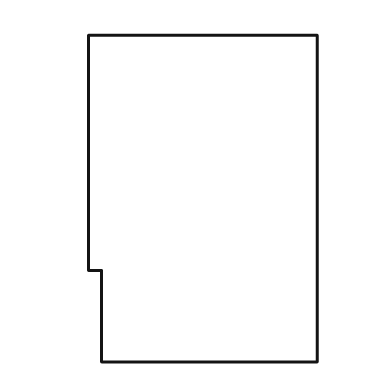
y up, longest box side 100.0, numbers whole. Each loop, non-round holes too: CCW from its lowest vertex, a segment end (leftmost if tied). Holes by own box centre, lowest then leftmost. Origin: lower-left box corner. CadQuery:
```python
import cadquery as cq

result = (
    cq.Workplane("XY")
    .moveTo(4.0, 0.0)
    .lineTo(70.0, 0.0)
    .lineTo(70.0, 100.0)
    .lineTo(0.0, 100.0)
    .lineTo(0.0, 28.0)
    .lineTo(4.0, 28.0)
    .close()
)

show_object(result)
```